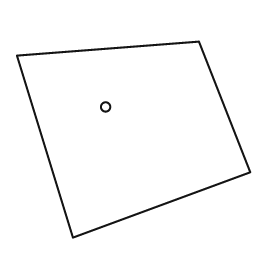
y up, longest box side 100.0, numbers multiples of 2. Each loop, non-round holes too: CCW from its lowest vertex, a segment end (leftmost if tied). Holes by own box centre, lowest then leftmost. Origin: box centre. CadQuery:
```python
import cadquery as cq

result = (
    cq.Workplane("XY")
    .moveTo(-26.0, -42.0)
    .lineTo(50.0, -14.0)
    .lineTo(28.0, 42.0)
    .lineTo(-50.0, 36.0)
    .close()
    .moveTo(-12.0, 14.0)
    .circle(2.0)
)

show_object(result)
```